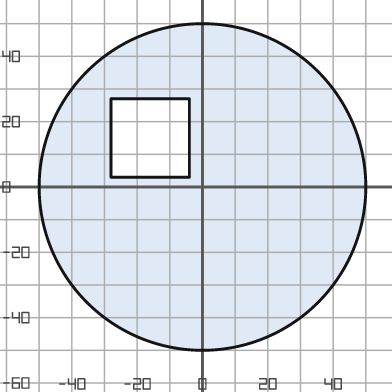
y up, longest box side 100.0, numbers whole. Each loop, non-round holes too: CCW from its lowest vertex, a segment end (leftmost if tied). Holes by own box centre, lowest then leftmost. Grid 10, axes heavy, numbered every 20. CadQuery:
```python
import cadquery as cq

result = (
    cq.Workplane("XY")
    .moveTo(0.0, 0.0)
    .circle(50.0)
    .moveTo(-28.0, 3.0)
    .lineTo(-4.0, 3.0)
    .lineTo(-4.0, 27.0)
    .lineTo(-28.0, 27.0)
    .close()
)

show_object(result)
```